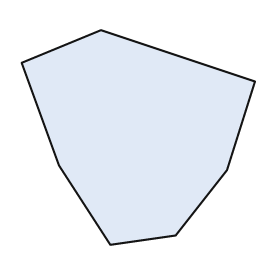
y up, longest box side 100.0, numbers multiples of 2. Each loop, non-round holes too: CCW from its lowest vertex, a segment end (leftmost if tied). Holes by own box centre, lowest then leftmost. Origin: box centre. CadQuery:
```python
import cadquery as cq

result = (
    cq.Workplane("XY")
    .moveTo(-12.0, -46.0)
    .lineTo(16.0, -42.0)
    .lineTo(38.0, -14.0)
    .lineTo(50.0, 24.0)
    .lineTo(-16.0, 46.0)
    .lineTo(-50.0, 32.0)
    .lineTo(-34.0, -12.0)
    .close()
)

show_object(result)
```